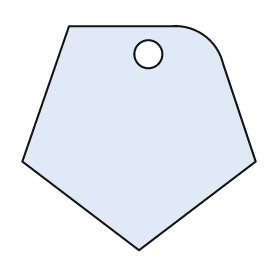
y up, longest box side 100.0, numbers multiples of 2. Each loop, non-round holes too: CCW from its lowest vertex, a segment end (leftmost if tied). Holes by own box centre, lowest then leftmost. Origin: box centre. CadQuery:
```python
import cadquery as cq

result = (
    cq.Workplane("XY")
    .moveTo(0.0, -48.0)
    .lineTo(50.0, -10.0)
    .lineTo(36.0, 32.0)
    .threePointArc((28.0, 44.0), (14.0, 48.0))
    .lineTo(-30.0, 48.0)
    .lineTo(-50.0, -10.0)
    .close()
    .moveTo(4.0, 36.0)
    .circle(6.0)
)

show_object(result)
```